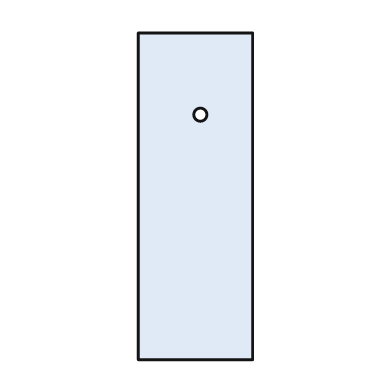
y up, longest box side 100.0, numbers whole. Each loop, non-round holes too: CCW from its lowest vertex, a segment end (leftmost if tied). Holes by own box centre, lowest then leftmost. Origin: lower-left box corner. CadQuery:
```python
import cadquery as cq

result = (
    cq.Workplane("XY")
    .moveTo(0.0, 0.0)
    .lineTo(35.0, 0.0)
    .lineTo(35.0, 100.0)
    .lineTo(0.0, 100.0)
    .close()
    .moveTo(19.0, 75.0)
    .circle(2.0)
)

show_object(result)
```